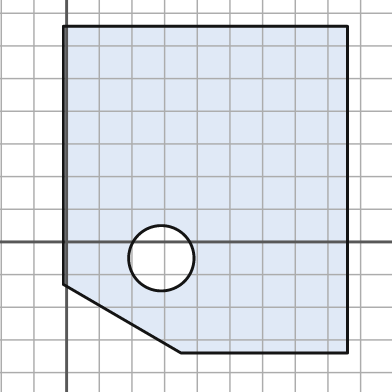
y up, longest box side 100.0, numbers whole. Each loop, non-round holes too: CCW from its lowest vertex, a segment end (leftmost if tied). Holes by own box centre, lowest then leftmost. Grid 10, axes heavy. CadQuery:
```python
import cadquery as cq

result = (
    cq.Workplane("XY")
    .moveTo(35.0, -34.0)
    .lineTo(86.0, -34.0)
    .lineTo(86.0, 66.0)
    .lineTo(-1.0, 66.0)
    .lineTo(-1.0, -13.0)
    .close()
    .moveTo(29.0, -5.0)
    .circle(10.0)
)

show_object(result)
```